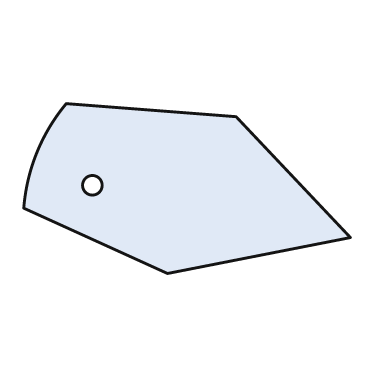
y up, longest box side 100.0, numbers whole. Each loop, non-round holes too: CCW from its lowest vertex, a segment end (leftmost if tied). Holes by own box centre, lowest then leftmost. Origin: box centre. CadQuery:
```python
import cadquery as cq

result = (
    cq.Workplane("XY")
    .moveTo(-6.0, -26.0)
    .lineTo(50.0, -15.0)
    .lineTo(15.0, 22.0)
    .lineTo(-37.0, 26.0)
    .threePointArc((-46.0, 11.0), (-50.0, -6.0))
    .close()
    .moveTo(-29.0, 1.0)
    .circle(3.0)
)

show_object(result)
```